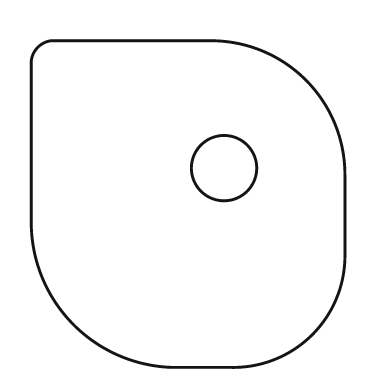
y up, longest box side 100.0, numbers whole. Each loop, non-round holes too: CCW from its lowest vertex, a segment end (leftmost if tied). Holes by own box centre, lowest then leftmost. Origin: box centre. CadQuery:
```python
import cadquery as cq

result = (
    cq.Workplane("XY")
    .moveTo(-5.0, -50.0)
    .lineTo(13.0, -50.0)
    .threePointArc((38.0, -40.0), (48.0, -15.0))
    .lineTo(48.0, 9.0)
    .threePointArc((36.0, 38.0), (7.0, 50.0))
    .lineTo(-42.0, 50.0)
    .threePointArc((-46.0, 48.0), (-48.0, 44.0))
    .lineTo(-48.0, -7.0)
    .threePointArc((-35.0, -37.0), (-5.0, -50.0))
    .close()
    .moveTo(11.0, 11.0)
    .circle(10.0)
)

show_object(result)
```